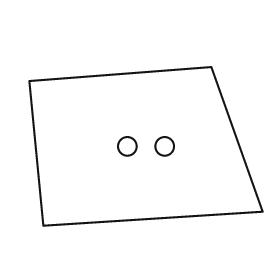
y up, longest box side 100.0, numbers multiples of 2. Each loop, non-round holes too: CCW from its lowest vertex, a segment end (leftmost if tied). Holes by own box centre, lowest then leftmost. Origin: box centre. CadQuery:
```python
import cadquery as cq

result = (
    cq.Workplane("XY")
    .moveTo(-44.0, -34.0)
    .lineTo(50.0, -28.0)
    .lineTo(28.0, 34.0)
    .lineTo(-50.0, 28.0)
    .close()
    .moveTo(-8.0, 0.0)
    .circle(4.0)
    .moveTo(8.0, 0.0)
    .circle(4.0)
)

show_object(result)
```